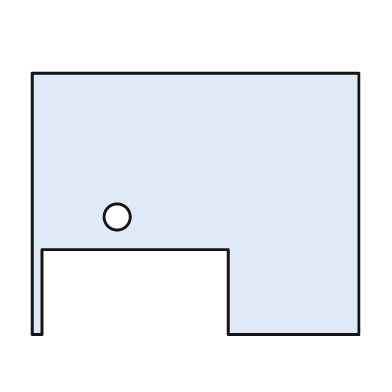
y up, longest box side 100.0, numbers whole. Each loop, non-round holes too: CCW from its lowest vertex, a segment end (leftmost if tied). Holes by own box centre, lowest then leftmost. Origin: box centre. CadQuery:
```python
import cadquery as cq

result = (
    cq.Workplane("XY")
    .moveTo(-50.0, -40.0)
    .lineTo(-47.0, -40.0)
    .lineTo(-47.0, -14.0)
    .lineTo(10.0, -14.0)
    .lineTo(10.0, -40.0)
    .lineTo(50.0, -40.0)
    .lineTo(50.0, 40.0)
    .lineTo(-50.0, 40.0)
    .close()
    .moveTo(-24.0, -4.0)
    .circle(4.0)
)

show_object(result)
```